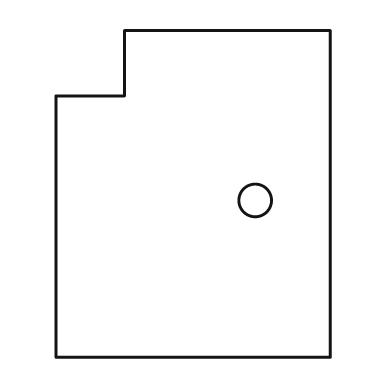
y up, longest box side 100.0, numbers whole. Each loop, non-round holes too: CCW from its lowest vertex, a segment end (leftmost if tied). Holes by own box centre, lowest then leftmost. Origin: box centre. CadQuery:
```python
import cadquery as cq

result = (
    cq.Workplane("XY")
    .moveTo(-42.0, -50.0)
    .lineTo(42.0, -50.0)
    .lineTo(42.0, 50.0)
    .lineTo(-21.0, 50.0)
    .lineTo(-21.0, 30.0)
    .lineTo(-42.0, 30.0)
    .close()
    .moveTo(19.0, -2.0)
    .circle(5.0)
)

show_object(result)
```